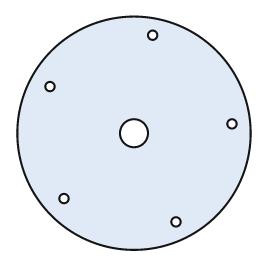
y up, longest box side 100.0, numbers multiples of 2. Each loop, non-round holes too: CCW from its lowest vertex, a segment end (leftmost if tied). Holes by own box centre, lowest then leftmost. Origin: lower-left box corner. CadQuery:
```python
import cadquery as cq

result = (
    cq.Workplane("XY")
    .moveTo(50.0, 50.0)
    .circle(50.0)
    .moveTo(68.0, 12.0)
    .circle(2.0)
    .moveTo(20.0, 22.0)
    .circle(2.0)
    .moveTo(50.0, 50.0)
    .circle(6.0)
    .moveTo(92.0, 54.0)
    .circle(2.0)
    .moveTo(14.0, 70.0)
    .circle(2.0)
    .moveTo(58.0, 92.0)
    .circle(2.0)
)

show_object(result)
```